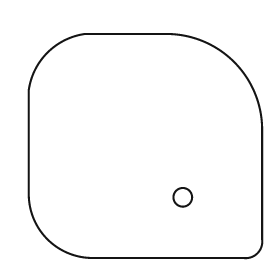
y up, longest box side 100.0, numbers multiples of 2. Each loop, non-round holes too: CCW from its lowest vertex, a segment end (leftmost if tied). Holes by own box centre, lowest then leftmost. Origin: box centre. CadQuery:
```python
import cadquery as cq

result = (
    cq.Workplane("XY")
    .moveTo(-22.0, -48.0)
    .lineTo(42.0, -48.0)
    .threePointArc((48.0, -46.0), (50.0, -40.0))
    .lineTo(50.0, 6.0)
    .threePointArc((38.0, 36.0), (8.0, 48.0))
    .lineTo(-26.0, 48.0)
    .threePointArc((-42.0, 40.0), (-50.0, 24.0))
    .lineTo(-50.0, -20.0)
    .threePointArc((-42.0, -40.0), (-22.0, -48.0))
    .close()
    .moveTo(16.0, -22.0)
    .circle(4.0)
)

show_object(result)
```